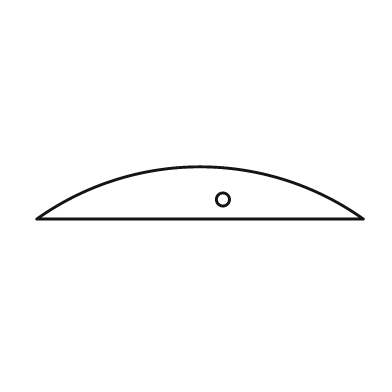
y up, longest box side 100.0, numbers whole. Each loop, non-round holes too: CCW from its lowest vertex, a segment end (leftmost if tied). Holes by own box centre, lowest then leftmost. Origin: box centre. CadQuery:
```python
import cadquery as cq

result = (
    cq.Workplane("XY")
    .moveTo(-50.0, -8.0)
    .lineTo(50.0, -8.0)
    .threePointArc((0.0, 8.0), (-50.0, -8.0))
    .close()
    .moveTo(7.0, -2.0)
    .circle(2.0)
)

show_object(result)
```